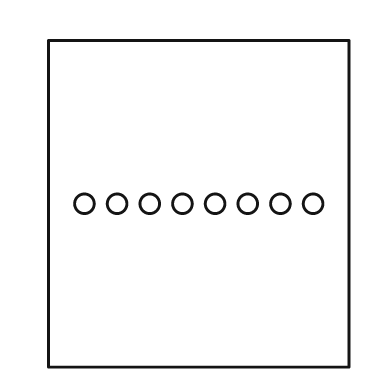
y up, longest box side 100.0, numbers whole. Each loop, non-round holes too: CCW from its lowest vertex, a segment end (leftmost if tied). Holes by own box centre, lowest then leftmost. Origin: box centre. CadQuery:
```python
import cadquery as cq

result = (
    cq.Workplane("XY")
    .moveTo(-46.0, -50.0)
    .lineTo(46.0, -50.0)
    .lineTo(46.0, 50.0)
    .lineTo(-46.0, 50.0)
    .close()
    .moveTo(-35.0, 0.0)
    .circle(3.0)
    .moveTo(-25.0, 0.0)
    .circle(3.0)
    .moveTo(-15.0, 0.0)
    .circle(3.0)
    .moveTo(-5.0, 0.0)
    .circle(3.0)
    .moveTo(5.0, 0.0)
    .circle(3.0)
    .moveTo(15.0, 0.0)
    .circle(3.0)
    .moveTo(25.0, 0.0)
    .circle(3.0)
    .moveTo(35.0, 0.0)
    .circle(3.0)
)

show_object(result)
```